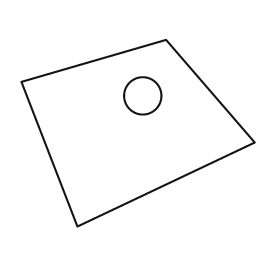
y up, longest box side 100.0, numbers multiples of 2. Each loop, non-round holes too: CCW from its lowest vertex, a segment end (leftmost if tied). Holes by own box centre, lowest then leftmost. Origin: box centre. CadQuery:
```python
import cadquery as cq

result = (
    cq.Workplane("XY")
    .moveTo(-26.0, -40.0)
    .lineTo(50.0, -4.0)
    .lineTo(12.0, 40.0)
    .lineTo(-50.0, 22.0)
    .close()
    .moveTo(2.0, 16.0)
    .circle(8.0)
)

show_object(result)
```